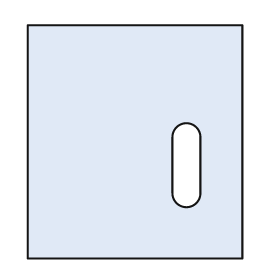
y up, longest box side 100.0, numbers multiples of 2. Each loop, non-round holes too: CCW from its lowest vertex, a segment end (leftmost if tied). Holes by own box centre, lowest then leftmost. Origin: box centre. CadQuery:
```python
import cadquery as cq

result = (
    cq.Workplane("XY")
    .moveTo(-46.0, -50.0)
    .lineTo(46.0, -50.0)
    .lineTo(46.0, 50.0)
    .lineTo(-46.0, 50.0)
    .close()
    .moveTo(16.0, -22.0)
    .threePointArc((22.0, -28.0), (28.0, -22.0))
    .lineTo(28.0, 2.0)
    .threePointArc((22.0, 8.0), (16.0, 2.0))
    .close()
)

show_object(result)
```